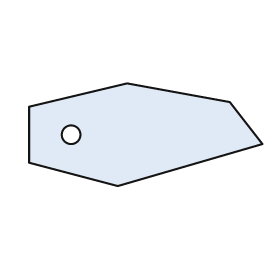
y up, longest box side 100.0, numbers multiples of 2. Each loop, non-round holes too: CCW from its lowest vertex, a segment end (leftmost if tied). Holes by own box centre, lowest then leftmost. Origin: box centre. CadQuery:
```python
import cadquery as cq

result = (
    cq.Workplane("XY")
    .moveTo(-12.0, -22.0)
    .lineTo(50.0, -4.0)
    .lineTo(36.0, 14.0)
    .lineTo(-8.0, 22.0)
    .lineTo(-50.0, 12.0)
    .lineTo(-50.0, -12.0)
    .close()
    .moveTo(-32.0, 0.0)
    .circle(4.0)
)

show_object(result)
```